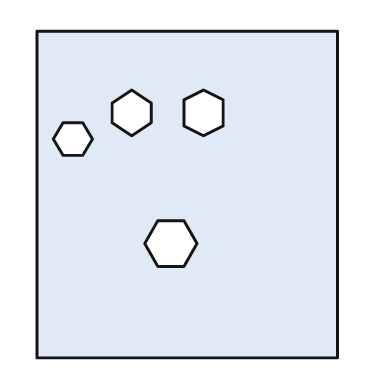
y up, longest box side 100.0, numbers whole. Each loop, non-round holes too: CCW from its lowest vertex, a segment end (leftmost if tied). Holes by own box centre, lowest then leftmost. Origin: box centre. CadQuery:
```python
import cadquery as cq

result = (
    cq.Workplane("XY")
    .moveTo(-46.0, -50.0)
    .lineTo(46.0, -50.0)
    .lineTo(46.0, 50.0)
    .lineTo(-46.0, 50.0)
    .close()
    .moveTo(-9.0, -22.0)
    .lineTo(-1.0, -22.0)
    .lineTo(3.0, -15.0)
    .lineTo(-1.0, -8.0)
    .lineTo(-9.0, -8.0)
    .lineTo(-13.0, -15.0)
    .close()
    .moveTo(-38.0, 12.0)
    .lineTo(-32.0, 12.0)
    .lineTo(-29.0, 17.0)
    .lineTo(-32.0, 22.0)
    .lineTo(-38.0, 22.0)
    .lineTo(-41.0, 17.0)
    .close()
    .moveTo(-17.0, 18.0)
    .lineTo(-11.0, 22.0)
    .lineTo(-11.0, 28.0)
    .lineTo(-17.0, 32.0)
    .lineTo(-23.0, 28.0)
    .lineTo(-23.0, 22.0)
    .close()
    .moveTo(5.0, 18.0)
    .lineTo(11.0, 21.0)
    .lineTo(11.0, 29.0)
    .lineTo(5.0, 32.0)
    .lineTo(-1.0, 29.0)
    .lineTo(-1.0, 21.0)
    .close()
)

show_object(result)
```